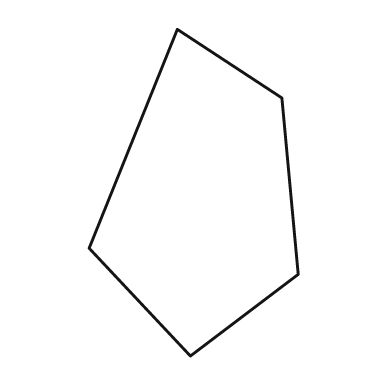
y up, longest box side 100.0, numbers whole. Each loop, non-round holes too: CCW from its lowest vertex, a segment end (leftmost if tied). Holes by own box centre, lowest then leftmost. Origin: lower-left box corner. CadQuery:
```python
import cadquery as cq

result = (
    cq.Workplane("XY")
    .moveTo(31.0, 0.0)
    .lineTo(64.0, 25.0)
    .lineTo(59.0, 79.0)
    .lineTo(27.0, 100.0)
    .lineTo(0.0, 33.0)
    .close()
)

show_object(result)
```